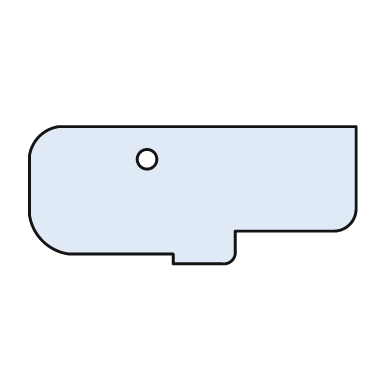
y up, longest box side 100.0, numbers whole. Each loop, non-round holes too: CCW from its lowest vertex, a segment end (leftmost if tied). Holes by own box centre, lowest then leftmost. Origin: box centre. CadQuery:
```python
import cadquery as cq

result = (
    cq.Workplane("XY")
    .moveTo(-6.0, -21.0)
    .lineTo(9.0, -21.0)
    .threePointArc((12.0, -20.0), (13.0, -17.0))
    .lineTo(13.0, -11.0)
    .lineTo(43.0, -11.0)
    .threePointArc((48.0, -9.0), (50.0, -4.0))
    .lineTo(50.0, 21.0)
    .lineTo(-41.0, 21.0)
    .threePointArc((-47.0, 18.0), (-50.0, 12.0))
    .lineTo(-50.0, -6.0)
    .threePointArc((-46.0, -14.0), (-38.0, -18.0))
    .lineTo(-6.0, -18.0)
    .close()
    .moveTo(-14.0, 11.0)
    .circle(3.0)
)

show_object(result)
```